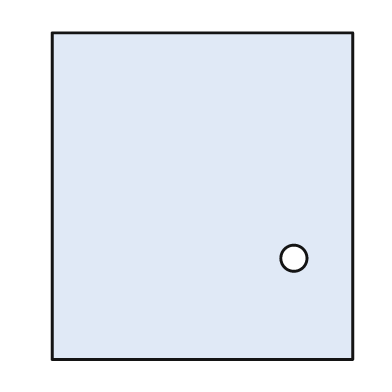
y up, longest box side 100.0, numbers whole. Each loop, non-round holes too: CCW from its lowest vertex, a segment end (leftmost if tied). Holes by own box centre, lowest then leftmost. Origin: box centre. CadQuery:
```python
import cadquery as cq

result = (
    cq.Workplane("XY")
    .moveTo(-46.0, -50.0)
    .lineTo(46.0, -50.0)
    .lineTo(46.0, 50.0)
    .lineTo(-46.0, 50.0)
    .close()
    .moveTo(28.0, -19.0)
    .circle(4.0)
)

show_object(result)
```